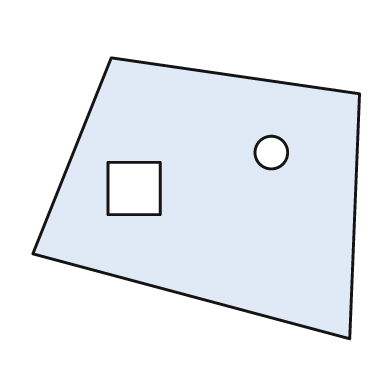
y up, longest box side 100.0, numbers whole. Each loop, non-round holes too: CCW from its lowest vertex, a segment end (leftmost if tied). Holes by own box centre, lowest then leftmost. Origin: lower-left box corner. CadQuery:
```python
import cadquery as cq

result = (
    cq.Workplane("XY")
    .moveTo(97.0, 0.0)
    .lineTo(100.0, 75.0)
    .lineTo(24.0, 86.0)
    .lineTo(0.0, 26.0)
    .close()
    .moveTo(23.0, 38.0)
    .lineTo(39.0, 38.0)
    .lineTo(39.0, 54.0)
    .lineTo(23.0, 54.0)
    .close()
    .moveTo(73.0, 57.0)
    .circle(5.0)
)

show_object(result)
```